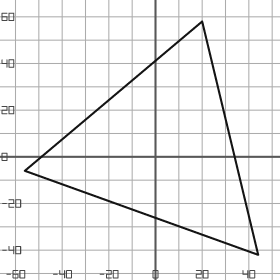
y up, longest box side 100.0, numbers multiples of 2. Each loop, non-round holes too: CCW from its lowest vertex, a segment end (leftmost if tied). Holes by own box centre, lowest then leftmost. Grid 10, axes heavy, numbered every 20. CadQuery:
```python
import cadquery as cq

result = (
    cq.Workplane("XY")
    .moveTo(44.0, -42.0)
    .lineTo(20.0, 58.0)
    .lineTo(-56.0, -6.0)
    .close()
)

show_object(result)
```